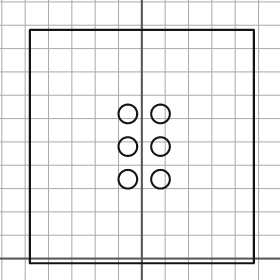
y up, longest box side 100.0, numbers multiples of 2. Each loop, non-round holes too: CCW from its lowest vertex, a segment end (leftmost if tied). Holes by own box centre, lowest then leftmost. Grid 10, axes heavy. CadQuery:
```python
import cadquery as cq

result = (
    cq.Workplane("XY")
    .moveTo(-48.0, -2.0)
    .lineTo(48.0, -2.0)
    .lineTo(48.0, 98.0)
    .lineTo(-48.0, 98.0)
    .close()
    .moveTo(-6.0, 34.0)
    .circle(4.0)
    .moveTo(8.0, 34.0)
    .circle(4.0)
    .moveTo(-6.0, 48.0)
    .circle(4.0)
    .moveTo(8.0, 48.0)
    .circle(4.0)
    .moveTo(-6.0, 62.0)
    .circle(4.0)
    .moveTo(8.0, 62.0)
    .circle(4.0)
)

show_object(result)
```